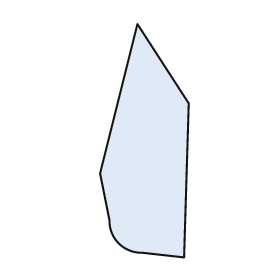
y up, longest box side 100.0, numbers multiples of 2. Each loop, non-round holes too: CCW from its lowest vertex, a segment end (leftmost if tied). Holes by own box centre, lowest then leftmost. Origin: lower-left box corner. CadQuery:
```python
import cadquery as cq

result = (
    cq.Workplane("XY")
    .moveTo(36.0, 0.0)
    .lineTo(38.0, 66.0)
    .lineTo(16.0, 100.0)
    .lineTo(0.0, 36.0)
    .lineTo(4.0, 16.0)
    .threePointArc((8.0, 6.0), (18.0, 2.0))
    .close()
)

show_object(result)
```